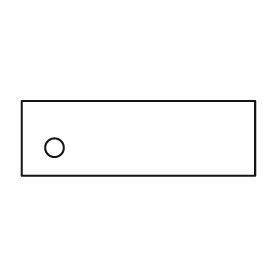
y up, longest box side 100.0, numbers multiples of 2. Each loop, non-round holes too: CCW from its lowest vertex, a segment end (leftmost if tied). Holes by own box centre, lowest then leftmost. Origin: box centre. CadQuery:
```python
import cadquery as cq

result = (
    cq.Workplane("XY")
    .moveTo(-50.0, -16.0)
    .lineTo(50.0, -16.0)
    .lineTo(50.0, 16.0)
    .lineTo(-50.0, 16.0)
    .close()
    .moveTo(-36.0, -4.0)
    .circle(4.0)
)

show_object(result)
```